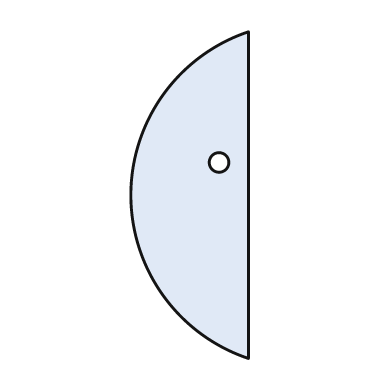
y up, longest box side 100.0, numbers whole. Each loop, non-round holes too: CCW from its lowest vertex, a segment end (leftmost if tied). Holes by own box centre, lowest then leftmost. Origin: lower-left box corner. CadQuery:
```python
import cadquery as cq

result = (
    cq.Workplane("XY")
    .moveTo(36.0, 0.0)
    .lineTo(36.0, 100.0)
    .threePointArc((0.0, 50.0), (36.0, 0.0))
    .close()
    .moveTo(27.0, 60.0)
    .circle(3.0)
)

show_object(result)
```